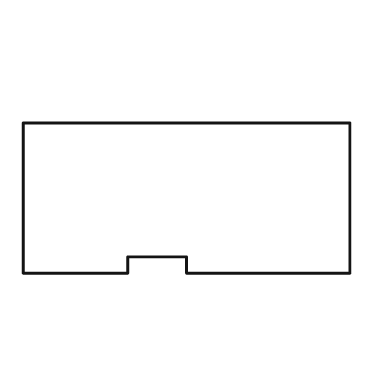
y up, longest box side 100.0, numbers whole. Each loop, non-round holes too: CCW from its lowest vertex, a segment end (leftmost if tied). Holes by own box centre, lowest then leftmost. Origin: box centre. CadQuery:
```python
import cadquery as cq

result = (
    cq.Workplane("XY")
    .moveTo(-50.0, -23.0)
    .lineTo(-18.0, -23.0)
    .lineTo(-18.0, -18.0)
    .lineTo(0.0, -18.0)
    .lineTo(0.0, -23.0)
    .lineTo(50.0, -23.0)
    .lineTo(50.0, 23.0)
    .lineTo(-50.0, 23.0)
    .close()
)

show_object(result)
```